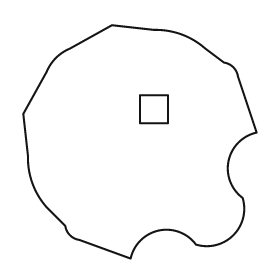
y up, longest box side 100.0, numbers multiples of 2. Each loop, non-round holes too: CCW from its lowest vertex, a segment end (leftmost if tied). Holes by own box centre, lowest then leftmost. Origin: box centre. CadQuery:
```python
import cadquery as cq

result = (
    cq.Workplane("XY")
    .moveTo(-4.0, -50.0)
    .threePointArc((8.0, -38.0), (24.0, -44.0))
    .threePointArc((40.0, -40.0), (44.0, -24.0))
    .threePointArc((38.0, -8.0), (50.0, 4.0))
    .lineTo(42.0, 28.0)
    .threePointArc((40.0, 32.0), (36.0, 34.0))
    .lineTo(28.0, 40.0)
    .threePointArc((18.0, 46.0), (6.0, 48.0))
    .lineTo(-12.0, 50.0)
    .lineTo(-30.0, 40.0)
    .threePointArc((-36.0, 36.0), (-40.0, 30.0))
    .lineTo(-50.0, 12.0)
    .lineTo(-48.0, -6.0)
    .threePointArc((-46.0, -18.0), (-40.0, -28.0))
    .lineTo(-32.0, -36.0)
    .threePointArc((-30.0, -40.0), (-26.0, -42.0))
    .close()
    .moveTo(0.0, 8.0)
    .lineTo(12.0, 8.0)
    .lineTo(12.0, 20.0)
    .lineTo(0.0, 20.0)
    .close()
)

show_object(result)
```